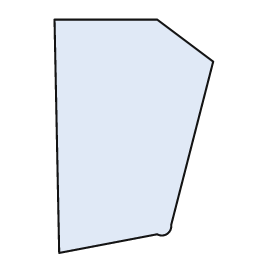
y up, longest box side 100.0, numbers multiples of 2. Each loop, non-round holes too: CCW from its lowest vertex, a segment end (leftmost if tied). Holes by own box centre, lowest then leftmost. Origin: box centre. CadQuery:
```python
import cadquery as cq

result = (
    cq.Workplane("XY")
    .moveTo(-32.0, -50.0)
    .lineTo(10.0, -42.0)
    .threePointArc((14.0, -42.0), (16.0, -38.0))
    .lineTo(34.0, 32.0)
    .lineTo(10.0, 50.0)
    .lineTo(-34.0, 50.0)
    .close()
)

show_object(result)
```